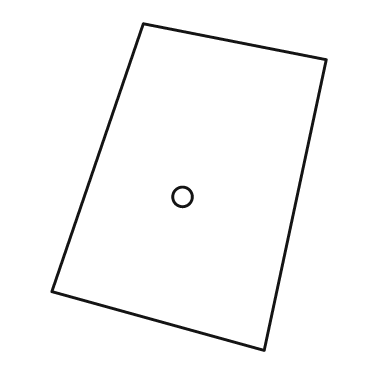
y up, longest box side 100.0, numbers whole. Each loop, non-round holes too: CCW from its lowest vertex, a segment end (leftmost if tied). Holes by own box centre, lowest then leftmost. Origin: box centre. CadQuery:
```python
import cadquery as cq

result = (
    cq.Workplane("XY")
    .moveTo(23.0, -50.0)
    .lineTo(42.0, 39.0)
    .lineTo(-14.0, 50.0)
    .lineTo(-42.0, -32.0)
    .close()
    .moveTo(-2.0, -3.0)
    .circle(3.0)
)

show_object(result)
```